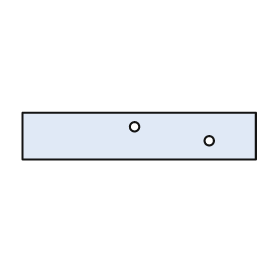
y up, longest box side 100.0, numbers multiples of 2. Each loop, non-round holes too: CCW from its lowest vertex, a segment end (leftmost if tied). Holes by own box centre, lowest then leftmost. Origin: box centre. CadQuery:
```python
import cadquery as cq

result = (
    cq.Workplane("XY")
    .moveTo(-50.0, -10.0)
    .lineTo(50.0, -10.0)
    .lineTo(50.0, 10.0)
    .lineTo(-50.0, 10.0)
    .close()
    .moveTo(30.0, -2.0)
    .circle(2.0)
    .moveTo(-2.0, 4.0)
    .circle(2.0)
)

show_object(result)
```